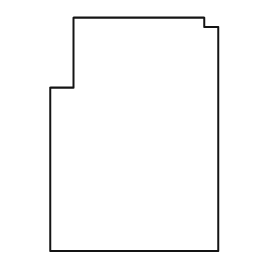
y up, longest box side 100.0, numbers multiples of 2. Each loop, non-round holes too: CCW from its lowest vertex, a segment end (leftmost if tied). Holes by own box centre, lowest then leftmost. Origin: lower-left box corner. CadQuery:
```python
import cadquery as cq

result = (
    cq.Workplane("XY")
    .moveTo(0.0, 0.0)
    .lineTo(72.0, 0.0)
    .lineTo(72.0, 96.0)
    .lineTo(66.0, 96.0)
    .lineTo(66.0, 100.0)
    .lineTo(10.0, 100.0)
    .lineTo(10.0, 70.0)
    .lineTo(0.0, 70.0)
    .close()
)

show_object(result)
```